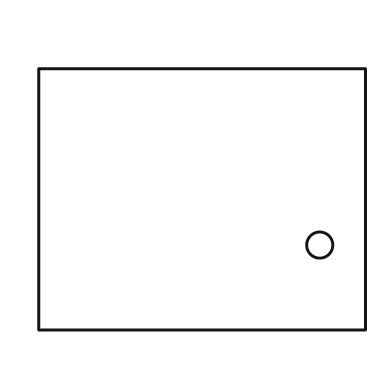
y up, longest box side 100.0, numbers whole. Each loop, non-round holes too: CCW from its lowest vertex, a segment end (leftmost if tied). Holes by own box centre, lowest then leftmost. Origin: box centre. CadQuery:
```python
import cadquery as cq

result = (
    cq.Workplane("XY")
    .moveTo(-50.0, -40.0)
    .lineTo(50.0, -40.0)
    .lineTo(50.0, 40.0)
    .lineTo(-50.0, 40.0)
    .close()
    .moveTo(36.0, -14.0)
    .circle(4.0)
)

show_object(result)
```